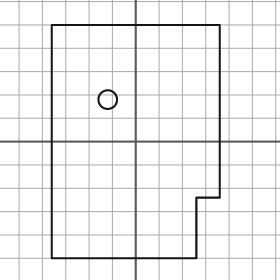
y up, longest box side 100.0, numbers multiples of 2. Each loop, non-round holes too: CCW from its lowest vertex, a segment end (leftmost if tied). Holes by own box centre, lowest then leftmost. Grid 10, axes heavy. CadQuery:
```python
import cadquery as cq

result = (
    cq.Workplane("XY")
    .moveTo(-36.0, -50.0)
    .lineTo(26.0, -50.0)
    .lineTo(26.0, -24.0)
    .lineTo(36.0, -24.0)
    .lineTo(36.0, 50.0)
    .lineTo(-36.0, 50.0)
    .close()
    .moveTo(-12.0, 18.0)
    .circle(4.0)
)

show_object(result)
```